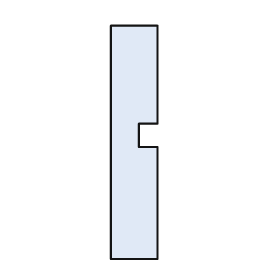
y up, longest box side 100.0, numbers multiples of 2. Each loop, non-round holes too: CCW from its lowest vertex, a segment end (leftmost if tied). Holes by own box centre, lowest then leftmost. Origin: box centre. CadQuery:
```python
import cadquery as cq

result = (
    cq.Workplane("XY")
    .moveTo(-10.0, -50.0)
    .lineTo(10.0, -50.0)
    .lineTo(10.0, -2.0)
    .lineTo(2.0, -2.0)
    .lineTo(2.0, 8.0)
    .lineTo(10.0, 8.0)
    .lineTo(10.0, 50.0)
    .lineTo(-10.0, 50.0)
    .close()
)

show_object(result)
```